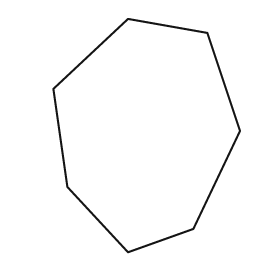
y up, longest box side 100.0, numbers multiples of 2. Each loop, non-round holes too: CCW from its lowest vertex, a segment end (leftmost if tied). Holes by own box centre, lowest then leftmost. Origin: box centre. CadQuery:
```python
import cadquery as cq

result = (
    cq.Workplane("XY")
    .moveTo(-8.0, -50.0)
    .lineTo(20.0, -40.0)
    .lineTo(40.0, 2.0)
    .lineTo(26.0, 44.0)
    .lineTo(-8.0, 50.0)
    .lineTo(-40.0, 20.0)
    .lineTo(-34.0, -22.0)
    .close()
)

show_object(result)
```